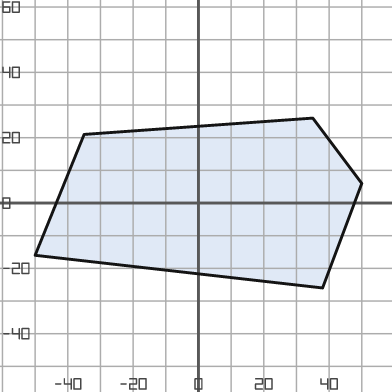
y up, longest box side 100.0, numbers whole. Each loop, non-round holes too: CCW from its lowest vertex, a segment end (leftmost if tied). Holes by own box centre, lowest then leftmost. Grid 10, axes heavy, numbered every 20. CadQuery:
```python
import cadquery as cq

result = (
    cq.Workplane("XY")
    .moveTo(38.0, -26.0)
    .lineTo(50.0, 6.0)
    .lineTo(35.0, 26.0)
    .lineTo(-35.0, 21.0)
    .lineTo(-50.0, -16.0)
    .close()
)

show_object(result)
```